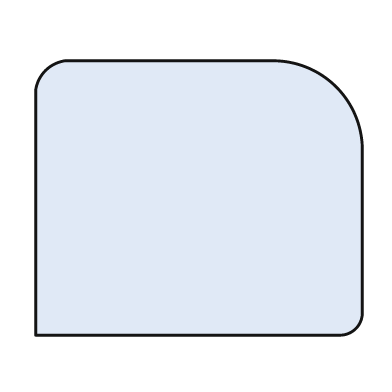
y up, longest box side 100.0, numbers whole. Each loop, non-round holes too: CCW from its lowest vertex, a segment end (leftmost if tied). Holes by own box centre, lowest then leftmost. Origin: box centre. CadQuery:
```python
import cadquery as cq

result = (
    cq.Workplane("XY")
    .moveTo(-50.0, -42.0)
    .lineTo(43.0, -42.0)
    .threePointArc((48.0, -40.0), (50.0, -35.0))
    .lineTo(50.0, 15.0)
    .threePointArc((42.0, 34.0), (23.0, 42.0))
    .lineTo(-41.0, 42.0)
    .threePointArc((-47.0, 39.0), (-50.0, 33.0))
    .close()
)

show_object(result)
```